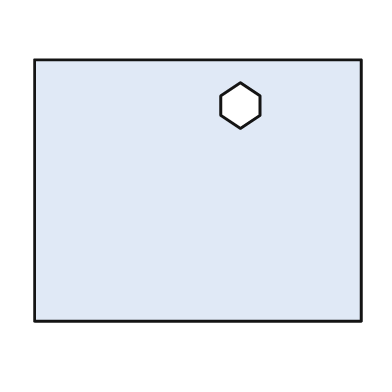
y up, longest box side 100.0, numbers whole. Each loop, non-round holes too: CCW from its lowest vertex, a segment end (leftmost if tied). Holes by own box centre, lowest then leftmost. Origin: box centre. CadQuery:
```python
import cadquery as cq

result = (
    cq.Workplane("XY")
    .moveTo(-50.0, -40.0)
    .lineTo(50.0, -40.0)
    .lineTo(50.0, 40.0)
    .lineTo(-50.0, 40.0)
    .close()
    .moveTo(13.0, 19.0)
    .lineTo(19.0, 23.0)
    .lineTo(19.0, 29.0)
    .lineTo(13.0, 33.0)
    .lineTo(7.0, 29.0)
    .lineTo(7.0, 23.0)
    .close()
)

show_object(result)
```